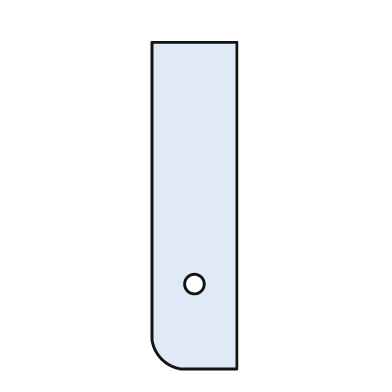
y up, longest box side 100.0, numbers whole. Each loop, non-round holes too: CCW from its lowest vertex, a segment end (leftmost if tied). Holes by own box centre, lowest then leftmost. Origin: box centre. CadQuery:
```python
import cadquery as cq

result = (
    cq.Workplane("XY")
    .moveTo(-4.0, -50.0)
    .lineTo(13.0, -50.0)
    .lineTo(13.0, 50.0)
    .lineTo(-13.0, 50.0)
    .lineTo(-13.0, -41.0)
    .threePointArc((-10.0, -47.0), (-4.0, -50.0))
    .close()
    .moveTo(0.0, -24.0)
    .circle(3.0)
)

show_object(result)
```